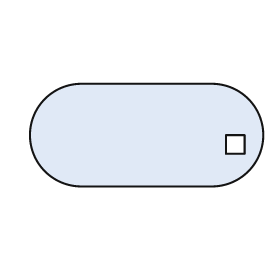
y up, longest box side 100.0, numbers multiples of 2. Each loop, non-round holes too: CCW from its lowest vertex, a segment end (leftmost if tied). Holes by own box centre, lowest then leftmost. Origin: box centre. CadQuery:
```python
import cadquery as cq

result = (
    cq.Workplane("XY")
    .moveTo(-28.0, -22.0)
    .lineTo(28.0, -22.0)
    .threePointArc((50.0, 0.0), (28.0, 22.0))
    .lineTo(-28.0, 22.0)
    .threePointArc((-50.0, 0.0), (-28.0, -22.0))
    .close()
    .moveTo(34.0, -8.0)
    .lineTo(42.0, -8.0)
    .lineTo(42.0, 0.0)
    .lineTo(34.0, 0.0)
    .close()
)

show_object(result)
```